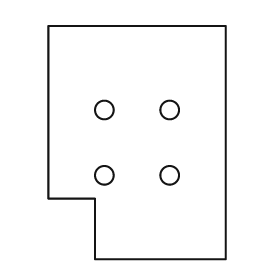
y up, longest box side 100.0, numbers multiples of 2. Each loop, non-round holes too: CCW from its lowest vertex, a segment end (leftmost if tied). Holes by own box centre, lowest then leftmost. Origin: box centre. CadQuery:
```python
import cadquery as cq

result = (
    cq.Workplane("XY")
    .moveTo(-18.0, -50.0)
    .lineTo(38.0, -50.0)
    .lineTo(38.0, 50.0)
    .lineTo(-38.0, 50.0)
    .lineTo(-38.0, -24.0)
    .lineTo(-18.0, -24.0)
    .close()
    .moveTo(-14.0, -14.0)
    .circle(4.0)
    .moveTo(14.0, -14.0)
    .circle(4.0)
    .moveTo(-14.0, 14.0)
    .circle(4.0)
    .moveTo(14.0, 14.0)
    .circle(4.0)
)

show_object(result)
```